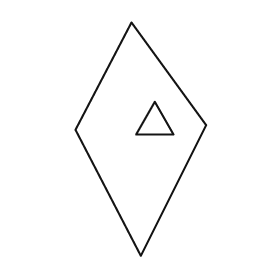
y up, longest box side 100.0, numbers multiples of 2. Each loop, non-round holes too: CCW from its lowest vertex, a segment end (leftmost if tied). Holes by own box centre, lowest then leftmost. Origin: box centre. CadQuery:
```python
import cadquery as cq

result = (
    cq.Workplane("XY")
    .moveTo(0.0, -50.0)
    .lineTo(28.0, 6.0)
    .lineTo(-4.0, 50.0)
    .lineTo(-28.0, 4.0)
    .close()
    .moveTo(-2.0, 2.0)
    .lineTo(14.0, 2.0)
    .lineTo(6.0, 16.0)
    .close()
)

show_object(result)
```